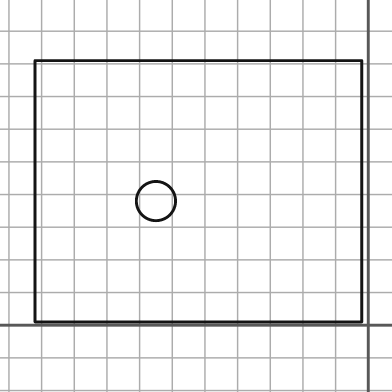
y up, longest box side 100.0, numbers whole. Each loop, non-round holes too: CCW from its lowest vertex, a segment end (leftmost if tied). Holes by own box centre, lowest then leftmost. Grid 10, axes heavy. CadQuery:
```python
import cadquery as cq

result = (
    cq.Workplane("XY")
    .moveTo(-102.0, 1.0)
    .lineTo(-2.0, 1.0)
    .lineTo(-2.0, 81.0)
    .lineTo(-102.0, 81.0)
    .close()
    .moveTo(-65.0, 38.0)
    .circle(6.0)
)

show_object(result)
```